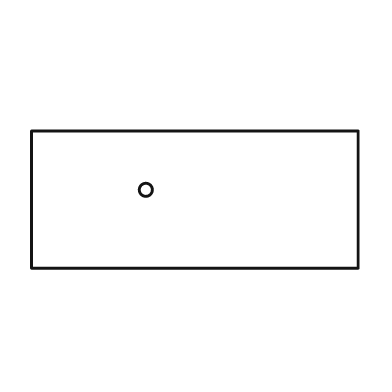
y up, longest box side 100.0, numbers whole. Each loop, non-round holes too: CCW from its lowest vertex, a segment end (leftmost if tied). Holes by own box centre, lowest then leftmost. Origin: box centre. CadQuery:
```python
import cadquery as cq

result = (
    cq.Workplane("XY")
    .moveTo(-50.0, -21.0)
    .lineTo(50.0, -21.0)
    .lineTo(50.0, 21.0)
    .lineTo(-50.0, 21.0)
    .close()
    .moveTo(-15.0, 3.0)
    .circle(2.0)
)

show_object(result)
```